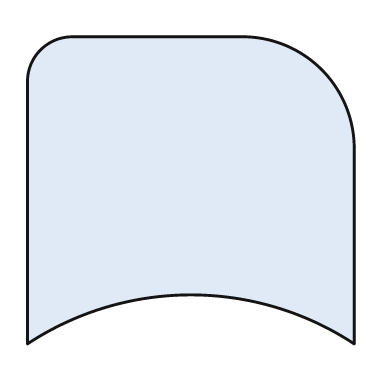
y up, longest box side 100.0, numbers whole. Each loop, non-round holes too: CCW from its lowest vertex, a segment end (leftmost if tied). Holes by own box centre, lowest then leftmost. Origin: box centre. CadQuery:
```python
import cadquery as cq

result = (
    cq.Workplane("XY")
    .moveTo(-50.0, -47.0)
    .threePointArc((0.0, -32.0), (50.0, -47.0))
    .lineTo(50.0, 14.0)
    .threePointArc((40.0, 37.0), (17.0, 47.0))
    .lineTo(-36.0, 47.0)
    .threePointArc((-46.0, 43.0), (-50.0, 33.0))
    .close()
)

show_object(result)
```